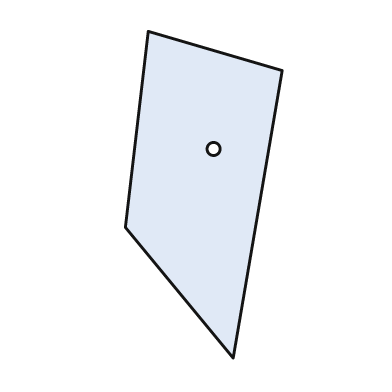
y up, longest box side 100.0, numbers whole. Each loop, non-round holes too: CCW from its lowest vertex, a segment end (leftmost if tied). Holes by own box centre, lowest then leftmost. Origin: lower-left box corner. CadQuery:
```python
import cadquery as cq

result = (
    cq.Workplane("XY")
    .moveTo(33.0, 0.0)
    .lineTo(48.0, 88.0)
    .lineTo(7.0, 100.0)
    .lineTo(0.0, 40.0)
    .close()
    .moveTo(27.0, 64.0)
    .circle(2.0)
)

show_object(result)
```